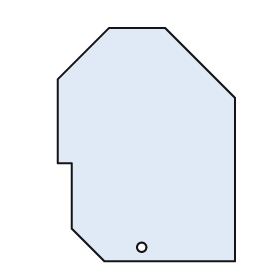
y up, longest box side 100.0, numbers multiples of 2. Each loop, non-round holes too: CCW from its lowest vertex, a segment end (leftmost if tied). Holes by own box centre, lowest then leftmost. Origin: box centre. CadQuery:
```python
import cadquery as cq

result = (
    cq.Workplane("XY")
    .moveTo(-18.0, -50.0)
    .lineTo(38.0, -50.0)
    .lineTo(38.0, 20.0)
    .lineTo(8.0, 50.0)
    .lineTo(-16.0, 50.0)
    .lineTo(-38.0, 28.0)
    .lineTo(-38.0, -8.0)
    .lineTo(-32.0, -8.0)
    .lineTo(-32.0, -36.0)
    .close()
    .moveTo(-2.0, -44.0)
    .circle(2.0)
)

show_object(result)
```